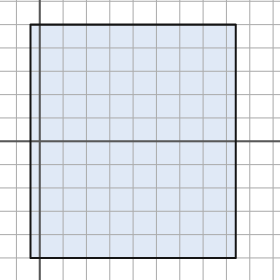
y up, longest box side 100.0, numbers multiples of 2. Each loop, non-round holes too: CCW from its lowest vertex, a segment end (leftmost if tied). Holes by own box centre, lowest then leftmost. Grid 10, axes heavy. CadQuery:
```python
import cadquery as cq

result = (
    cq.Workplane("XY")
    .moveTo(-4.0, -50.0)
    .lineTo(84.0, -50.0)
    .lineTo(84.0, 50.0)
    .lineTo(-4.0, 50.0)
    .close()
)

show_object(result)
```